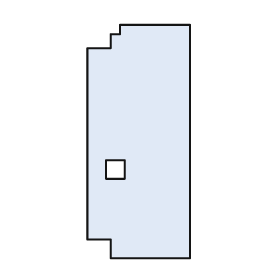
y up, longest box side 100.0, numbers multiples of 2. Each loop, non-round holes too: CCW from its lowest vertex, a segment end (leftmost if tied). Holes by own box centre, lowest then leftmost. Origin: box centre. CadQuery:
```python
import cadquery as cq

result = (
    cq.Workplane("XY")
    .moveTo(-12.0, -50.0)
    .lineTo(22.0, -50.0)
    .lineTo(22.0, 50.0)
    .lineTo(-8.0, 50.0)
    .lineTo(-8.0, 46.0)
    .lineTo(-12.0, 46.0)
    .lineTo(-12.0, 40.0)
    .lineTo(-22.0, 40.0)
    .lineTo(-22.0, -42.0)
    .lineTo(-12.0, -42.0)
    .close()
    .moveTo(-14.0, -16.0)
    .lineTo(-6.0, -16.0)
    .lineTo(-6.0, -8.0)
    .lineTo(-14.0, -8.0)
    .close()
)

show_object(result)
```